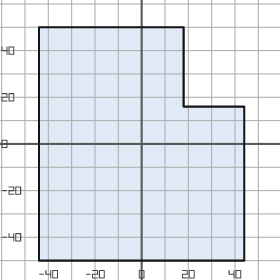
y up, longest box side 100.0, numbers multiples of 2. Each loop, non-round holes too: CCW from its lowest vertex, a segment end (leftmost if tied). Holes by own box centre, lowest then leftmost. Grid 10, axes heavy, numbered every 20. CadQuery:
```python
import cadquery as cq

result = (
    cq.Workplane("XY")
    .moveTo(-44.0, -50.0)
    .lineTo(44.0, -50.0)
    .lineTo(44.0, 16.0)
    .lineTo(18.0, 16.0)
    .lineTo(18.0, 50.0)
    .lineTo(-44.0, 50.0)
    .close()
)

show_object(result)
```